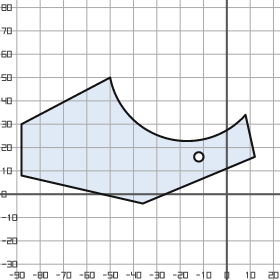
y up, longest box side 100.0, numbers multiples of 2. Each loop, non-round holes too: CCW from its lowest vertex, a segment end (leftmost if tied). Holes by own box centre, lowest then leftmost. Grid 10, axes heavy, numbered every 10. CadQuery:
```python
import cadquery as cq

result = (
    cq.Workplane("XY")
    .moveTo(-36.0, -4.0)
    .lineTo(12.0, 16.0)
    .lineTo(8.0, 34.0)
    .threePointArc((-26.0, 24.0), (-50.0, 50.0))
    .lineTo(-88.0, 30.0)
    .lineTo(-88.0, 8.0)
    .close()
    .moveTo(-12.0, 16.0)
    .circle(2.0)
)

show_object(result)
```